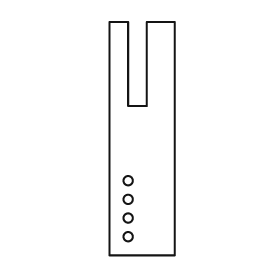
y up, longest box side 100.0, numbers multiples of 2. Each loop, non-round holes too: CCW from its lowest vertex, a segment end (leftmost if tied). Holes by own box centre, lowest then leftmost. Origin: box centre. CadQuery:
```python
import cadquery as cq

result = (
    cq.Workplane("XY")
    .moveTo(-14.0, -50.0)
    .lineTo(14.0, -50.0)
    .lineTo(14.0, 50.0)
    .lineTo(2.0, 50.0)
    .lineTo(2.0, 14.0)
    .lineTo(-6.0, 14.0)
    .lineTo(-6.0, 50.0)
    .lineTo(-14.0, 50.0)
    .close()
    .moveTo(-6.0, -42.0)
    .circle(2.0)
    .moveTo(-6.0, -34.0)
    .circle(2.0)
    .moveTo(-6.0, -26.0)
    .circle(2.0)
    .moveTo(-6.0, -18.0)
    .circle(2.0)
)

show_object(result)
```